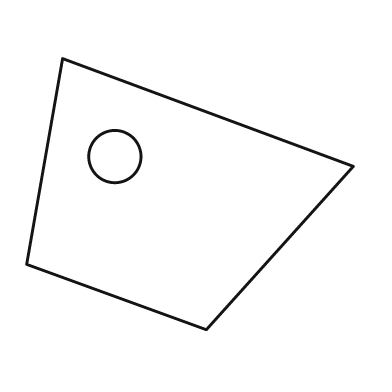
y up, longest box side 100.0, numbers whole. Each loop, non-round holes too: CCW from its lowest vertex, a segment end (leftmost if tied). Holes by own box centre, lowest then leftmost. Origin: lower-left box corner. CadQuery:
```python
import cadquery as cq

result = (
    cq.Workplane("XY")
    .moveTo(55.0, 0.0)
    .lineTo(100.0, 50.0)
    .lineTo(11.0, 83.0)
    .lineTo(0.0, 20.0)
    .close()
    .moveTo(27.0, 53.0)
    .circle(8.0)
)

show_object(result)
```